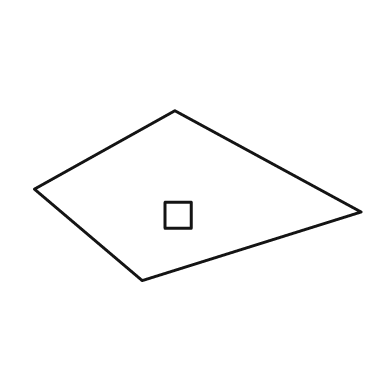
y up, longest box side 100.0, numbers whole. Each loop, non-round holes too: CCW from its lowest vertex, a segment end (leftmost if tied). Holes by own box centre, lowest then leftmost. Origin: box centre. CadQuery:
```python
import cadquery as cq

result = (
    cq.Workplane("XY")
    .moveTo(-17.0, -26.0)
    .lineTo(50.0, -5.0)
    .lineTo(-7.0, 26.0)
    .lineTo(-50.0, 2.0)
    .close()
    .moveTo(-10.0, -10.0)
    .lineTo(-2.0, -10.0)
    .lineTo(-2.0, -2.0)
    .lineTo(-10.0, -2.0)
    .close()
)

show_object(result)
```